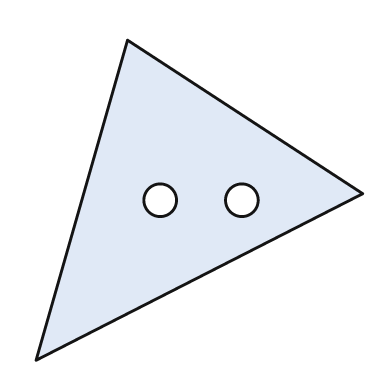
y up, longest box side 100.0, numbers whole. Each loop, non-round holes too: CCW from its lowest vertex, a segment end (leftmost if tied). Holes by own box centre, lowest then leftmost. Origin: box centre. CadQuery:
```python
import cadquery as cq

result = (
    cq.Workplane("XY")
    .moveTo(-50.0, -49.0)
    .lineTo(50.0, 2.0)
    .lineTo(-22.0, 49.0)
    .close()
    .moveTo(-12.0, 0.0)
    .circle(5.0)
    .moveTo(13.0, 0.0)
    .circle(5.0)
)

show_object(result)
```